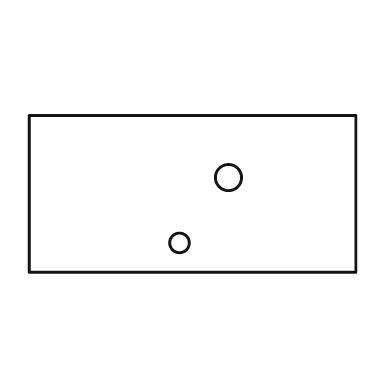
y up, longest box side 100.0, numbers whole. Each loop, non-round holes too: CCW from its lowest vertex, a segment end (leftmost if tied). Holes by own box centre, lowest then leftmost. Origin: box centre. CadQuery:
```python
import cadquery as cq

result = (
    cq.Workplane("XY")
    .moveTo(-50.0, -24.0)
    .lineTo(50.0, -24.0)
    .lineTo(50.0, 24.0)
    .lineTo(-50.0, 24.0)
    .close()
    .moveTo(-4.0, -15.0)
    .circle(3.0)
    .moveTo(11.0, 5.0)
    .circle(4.0)
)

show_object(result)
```